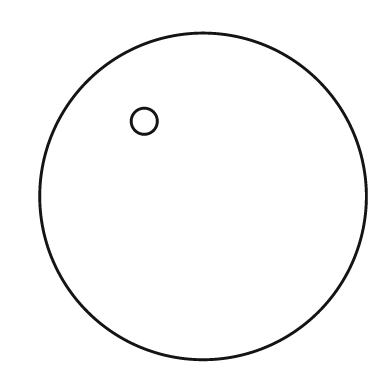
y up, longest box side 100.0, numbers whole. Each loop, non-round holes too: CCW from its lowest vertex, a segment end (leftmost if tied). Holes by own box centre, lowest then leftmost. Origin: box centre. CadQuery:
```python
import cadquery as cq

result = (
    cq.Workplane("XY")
    .moveTo(0.0, 0.0)
    .circle(50.0)
    .moveTo(-18.0, 23.0)
    .circle(4.0)
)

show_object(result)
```